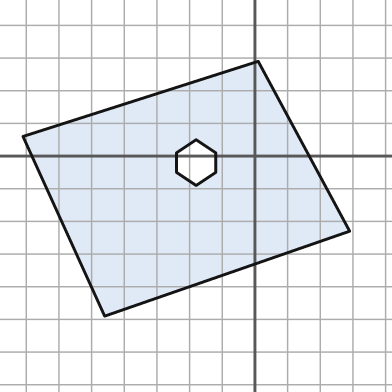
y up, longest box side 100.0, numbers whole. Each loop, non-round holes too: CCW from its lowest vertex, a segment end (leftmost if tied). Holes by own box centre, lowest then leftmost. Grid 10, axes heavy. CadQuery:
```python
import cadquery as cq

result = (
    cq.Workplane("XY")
    .moveTo(-46.0, -49.0)
    .lineTo(29.0, -23.0)
    .lineTo(1.0, 29.0)
    .lineTo(-71.0, 6.0)
    .close()
    .moveTo(-18.0, -9.0)
    .lineTo(-12.0, -5.0)
    .lineTo(-12.0, 1.0)
    .lineTo(-18.0, 5.0)
    .lineTo(-24.0, 1.0)
    .lineTo(-24.0, -5.0)
    .close()
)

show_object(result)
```